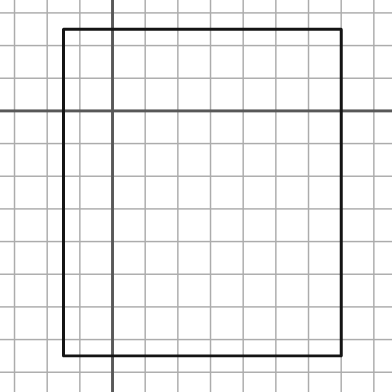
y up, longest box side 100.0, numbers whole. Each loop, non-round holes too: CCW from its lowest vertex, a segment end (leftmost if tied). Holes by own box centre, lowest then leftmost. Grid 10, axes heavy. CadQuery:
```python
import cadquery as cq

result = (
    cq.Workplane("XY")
    .moveTo(-15.0, -75.0)
    .lineTo(70.0, -75.0)
    .lineTo(70.0, 25.0)
    .lineTo(-15.0, 25.0)
    .close()
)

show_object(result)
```